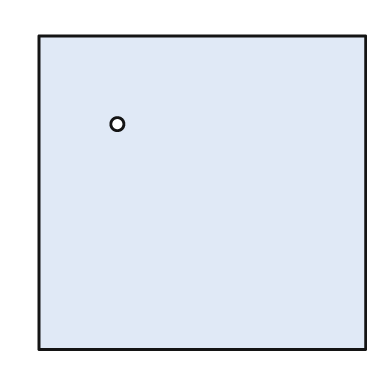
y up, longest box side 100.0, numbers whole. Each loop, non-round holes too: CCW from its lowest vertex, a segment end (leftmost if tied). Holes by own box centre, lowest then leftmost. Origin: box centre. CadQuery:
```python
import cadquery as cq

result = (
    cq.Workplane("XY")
    .moveTo(-50.0, -48.0)
    .lineTo(50.0, -48.0)
    .lineTo(50.0, 48.0)
    .lineTo(-50.0, 48.0)
    .close()
    .moveTo(-26.0, 21.0)
    .circle(2.0)
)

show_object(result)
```